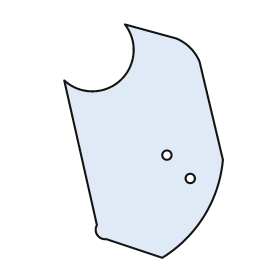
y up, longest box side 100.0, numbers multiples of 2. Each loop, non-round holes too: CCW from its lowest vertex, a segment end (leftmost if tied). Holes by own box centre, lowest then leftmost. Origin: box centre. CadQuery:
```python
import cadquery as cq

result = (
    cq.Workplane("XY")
    .moveTo(8.0, -50.0)
    .threePointArc((26.0, -32.0), (34.0, -8.0))
    .lineTo(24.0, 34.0)
    .threePointArc((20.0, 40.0), (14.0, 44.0))
    .lineTo(-8.0, 50.0)
    .threePointArc((-10.0, 26.0), (-34.0, 26.0))
    .lineTo(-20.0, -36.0)
    .threePointArc((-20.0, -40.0), (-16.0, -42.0))
    .close()
    .moveTo(20.0, -16.0)
    .circle(2.0)
    .moveTo(10.0, -6.0)
    .circle(2.0)
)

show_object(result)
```